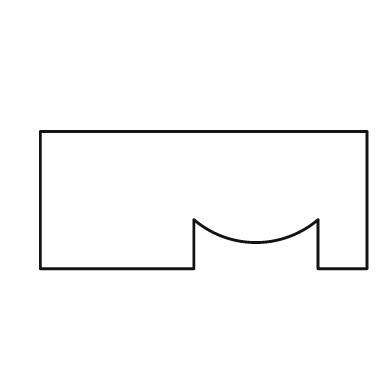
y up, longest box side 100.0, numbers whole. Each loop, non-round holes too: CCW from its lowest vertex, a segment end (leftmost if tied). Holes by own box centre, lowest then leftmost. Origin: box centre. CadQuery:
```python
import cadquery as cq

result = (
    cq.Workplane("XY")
    .moveTo(-50.0, -21.0)
    .lineTo(-3.0, -21.0)
    .lineTo(-3.0, -6.0)
    .threePointArc((16.0, -13.0), (35.0, -6.0))
    .lineTo(35.0, -21.0)
    .lineTo(50.0, -21.0)
    .lineTo(50.0, 21.0)
    .lineTo(-50.0, 21.0)
    .close()
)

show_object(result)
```